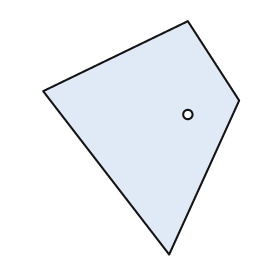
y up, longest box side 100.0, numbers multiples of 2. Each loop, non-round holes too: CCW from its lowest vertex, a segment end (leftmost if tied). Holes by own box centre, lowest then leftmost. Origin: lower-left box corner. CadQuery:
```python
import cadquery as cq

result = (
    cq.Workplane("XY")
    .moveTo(54.0, 0.0)
    .lineTo(84.0, 66.0)
    .lineTo(62.0, 100.0)
    .lineTo(0.0, 70.0)
    .close()
    .moveTo(62.0, 60.0)
    .circle(2.0)
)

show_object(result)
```